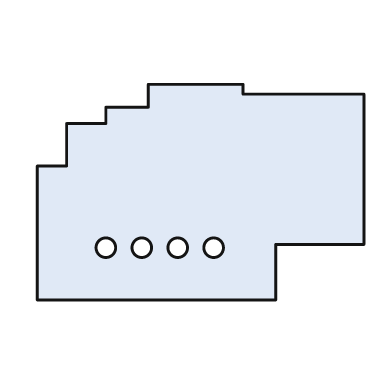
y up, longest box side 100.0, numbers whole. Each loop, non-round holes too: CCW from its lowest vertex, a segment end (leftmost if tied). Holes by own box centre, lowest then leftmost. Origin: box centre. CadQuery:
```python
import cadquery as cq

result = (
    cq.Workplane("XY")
    .moveTo(-50.0, -33.0)
    .lineTo(23.0, -33.0)
    .lineTo(23.0, -16.0)
    .lineTo(50.0, -16.0)
    .lineTo(50.0, 30.0)
    .lineTo(13.0, 30.0)
    .lineTo(13.0, 33.0)
    .lineTo(-16.0, 33.0)
    .lineTo(-16.0, 26.0)
    .lineTo(-29.0, 26.0)
    .lineTo(-29.0, 21.0)
    .lineTo(-41.0, 21.0)
    .lineTo(-41.0, 8.0)
    .lineTo(-50.0, 8.0)
    .close()
    .moveTo(-29.0, -17.0)
    .circle(3.0)
    .moveTo(-18.0, -17.0)
    .circle(3.0)
    .moveTo(-7.0, -17.0)
    .circle(3.0)
    .moveTo(4.0, -17.0)
    .circle(3.0)
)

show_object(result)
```